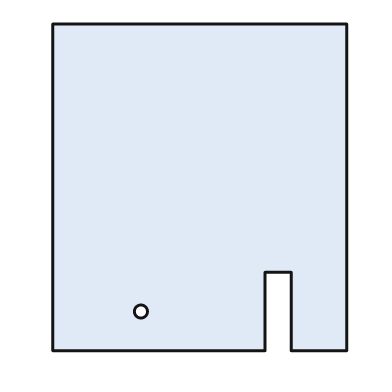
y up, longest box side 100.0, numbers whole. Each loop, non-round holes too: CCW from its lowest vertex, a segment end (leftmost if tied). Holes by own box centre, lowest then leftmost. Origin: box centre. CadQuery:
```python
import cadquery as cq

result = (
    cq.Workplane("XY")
    .moveTo(-45.0, -50.0)
    .lineTo(20.0, -50.0)
    .lineTo(20.0, -26.0)
    .lineTo(28.0, -26.0)
    .lineTo(28.0, -50.0)
    .lineTo(45.0, -50.0)
    .lineTo(45.0, 50.0)
    .lineTo(-45.0, 50.0)
    .close()
    .moveTo(-18.0, -38.0)
    .circle(2.0)
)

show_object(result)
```